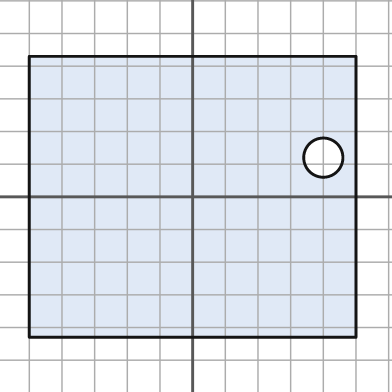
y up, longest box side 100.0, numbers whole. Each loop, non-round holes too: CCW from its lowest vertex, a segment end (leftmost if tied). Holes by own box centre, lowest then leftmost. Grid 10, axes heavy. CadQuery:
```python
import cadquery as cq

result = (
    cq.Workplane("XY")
    .moveTo(-50.0, -43.0)
    .lineTo(50.0, -43.0)
    .lineTo(50.0, 43.0)
    .lineTo(-50.0, 43.0)
    .close()
    .moveTo(40.0, 12.0)
    .circle(6.0)
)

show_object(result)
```